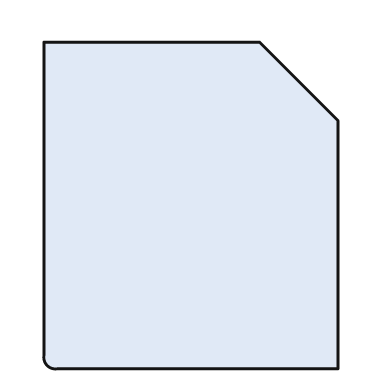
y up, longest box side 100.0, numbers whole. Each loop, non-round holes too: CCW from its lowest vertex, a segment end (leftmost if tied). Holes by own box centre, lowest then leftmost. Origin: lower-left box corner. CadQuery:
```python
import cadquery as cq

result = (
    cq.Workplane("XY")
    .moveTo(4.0, 0.0)
    .lineTo(90.0, 0.0)
    .lineTo(90.0, 76.0)
    .lineTo(66.0, 100.0)
    .lineTo(0.0, 100.0)
    .lineTo(0.0, 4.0)
    .threePointArc((1.0, 1.0), (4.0, 0.0))
    .close()
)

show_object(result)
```